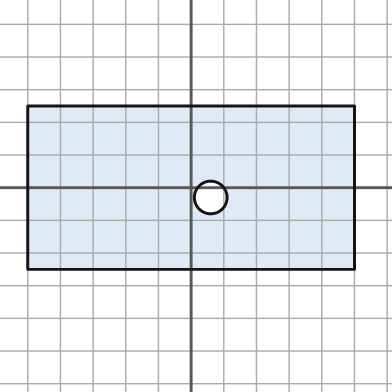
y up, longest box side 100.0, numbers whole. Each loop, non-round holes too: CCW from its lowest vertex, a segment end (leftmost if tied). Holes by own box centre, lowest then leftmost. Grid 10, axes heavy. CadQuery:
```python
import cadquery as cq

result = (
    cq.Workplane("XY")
    .moveTo(-50.0, -25.0)
    .lineTo(50.0, -25.0)
    .lineTo(50.0, 25.0)
    .lineTo(-50.0, 25.0)
    .close()
    .moveTo(6.0, -3.0)
    .circle(5.0)
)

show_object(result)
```